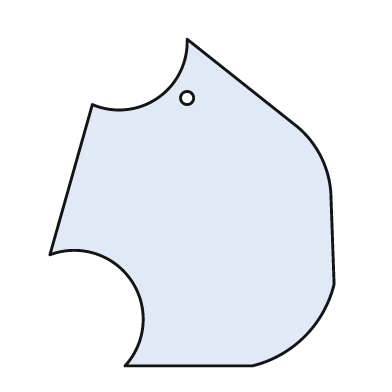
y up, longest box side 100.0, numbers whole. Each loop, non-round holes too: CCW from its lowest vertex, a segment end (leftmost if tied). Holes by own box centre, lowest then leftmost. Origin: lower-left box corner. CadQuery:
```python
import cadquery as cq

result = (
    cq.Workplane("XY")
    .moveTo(23.0, 0.0)
    .lineTo(62.0, 0.0)
    .threePointArc((78.0, 9.0), (87.0, 25.0))
    .lineTo(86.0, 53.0)
    .threePointArc((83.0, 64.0), (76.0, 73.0))
    .lineTo(42.0, 100.0)
    .threePointArc((33.0, 82.0), (13.0, 80.0))
    .lineTo(0.0, 34.0)
    .threePointArc((25.0, 26.0), (23.0, 0.0))
    .close()
    .moveTo(42.0, 82.0)
    .circle(2.0)
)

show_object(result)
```